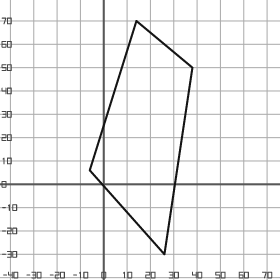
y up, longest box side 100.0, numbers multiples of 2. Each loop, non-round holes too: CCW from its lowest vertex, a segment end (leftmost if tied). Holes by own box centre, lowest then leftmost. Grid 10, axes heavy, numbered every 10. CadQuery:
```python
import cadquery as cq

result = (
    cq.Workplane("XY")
    .moveTo(26.0, -30.0)
    .lineTo(38.0, 50.0)
    .lineTo(14.0, 70.0)
    .lineTo(-6.0, 6.0)
    .close()
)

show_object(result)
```